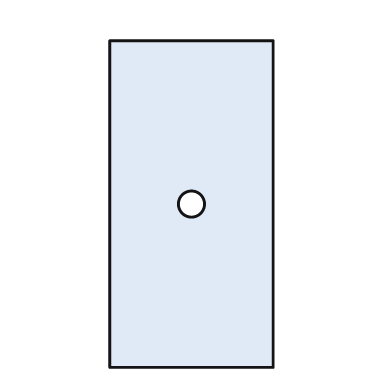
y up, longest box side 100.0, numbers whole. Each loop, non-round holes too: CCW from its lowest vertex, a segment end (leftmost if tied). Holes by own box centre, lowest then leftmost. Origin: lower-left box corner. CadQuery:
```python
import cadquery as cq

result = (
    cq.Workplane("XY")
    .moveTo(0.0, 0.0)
    .lineTo(50.0, 0.0)
    .lineTo(50.0, 100.0)
    .lineTo(0.0, 100.0)
    .close()
    .moveTo(25.0, 50.0)
    .circle(4.0)
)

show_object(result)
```